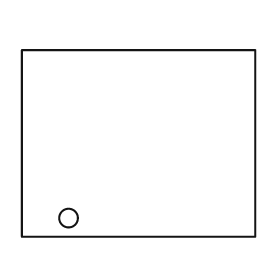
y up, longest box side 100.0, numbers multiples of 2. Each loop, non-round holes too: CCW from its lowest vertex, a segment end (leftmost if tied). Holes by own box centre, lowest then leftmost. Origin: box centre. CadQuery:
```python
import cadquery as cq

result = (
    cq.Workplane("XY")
    .moveTo(-50.0, -40.0)
    .lineTo(50.0, -40.0)
    .lineTo(50.0, 40.0)
    .lineTo(-50.0, 40.0)
    .close()
    .moveTo(-30.0, -32.0)
    .circle(4.0)
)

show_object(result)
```